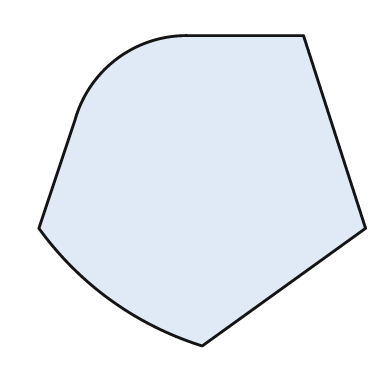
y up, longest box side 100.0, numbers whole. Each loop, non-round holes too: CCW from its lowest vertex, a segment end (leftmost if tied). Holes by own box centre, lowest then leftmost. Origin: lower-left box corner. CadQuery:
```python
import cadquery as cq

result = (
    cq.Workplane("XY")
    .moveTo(50.0, 0.0)
    .lineTo(100.0, 36.0)
    .lineTo(81.0, 95.0)
    .lineTo(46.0, 95.0)
    .threePointArc((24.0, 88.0), (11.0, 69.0))
    .lineTo(0.0, 36.0)
    .threePointArc((22.0, 14.0), (50.0, 0.0))
    .close()
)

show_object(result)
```